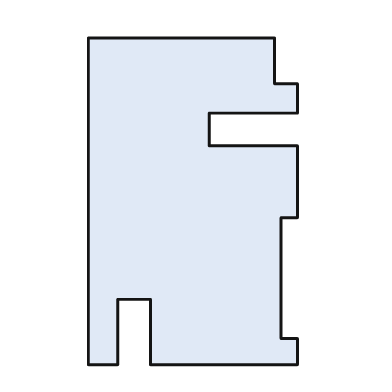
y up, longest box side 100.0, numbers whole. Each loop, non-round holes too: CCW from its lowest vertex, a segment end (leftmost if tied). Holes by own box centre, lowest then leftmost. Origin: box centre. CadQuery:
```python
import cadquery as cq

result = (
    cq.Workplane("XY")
    .moveTo(-32.0, -50.0)
    .lineTo(-23.0, -50.0)
    .lineTo(-23.0, -30.0)
    .lineTo(-13.0, -30.0)
    .lineTo(-13.0, -50.0)
    .lineTo(32.0, -50.0)
    .lineTo(32.0, -42.0)
    .lineTo(27.0, -42.0)
    .lineTo(27.0, -5.0)
    .lineTo(32.0, -5.0)
    .lineTo(32.0, 17.0)
    .lineTo(5.0, 17.0)
    .lineTo(5.0, 27.0)
    .lineTo(32.0, 27.0)
    .lineTo(32.0, 36.0)
    .lineTo(25.0, 36.0)
    .lineTo(25.0, 50.0)
    .lineTo(-32.0, 50.0)
    .close()
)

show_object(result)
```